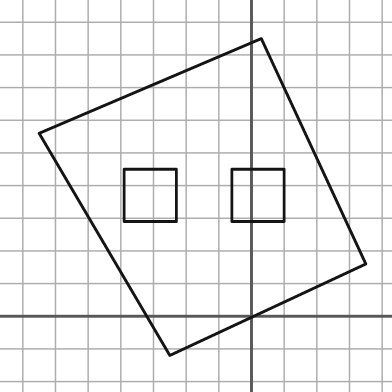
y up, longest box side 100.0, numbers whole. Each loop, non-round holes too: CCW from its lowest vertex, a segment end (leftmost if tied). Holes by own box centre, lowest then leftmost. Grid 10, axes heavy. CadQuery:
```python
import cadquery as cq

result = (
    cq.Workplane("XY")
    .moveTo(-25.0, -12.0)
    .lineTo(35.0, 16.0)
    .lineTo(3.0, 85.0)
    .lineTo(-65.0, 56.0)
    .close()
    .moveTo(-39.0, 29.0)
    .lineTo(-23.0, 29.0)
    .lineTo(-23.0, 45.0)
    .lineTo(-39.0, 45.0)
    .close()
    .moveTo(-6.0, 29.0)
    .lineTo(10.0, 29.0)
    .lineTo(10.0, 45.0)
    .lineTo(-6.0, 45.0)
    .close()
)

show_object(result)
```